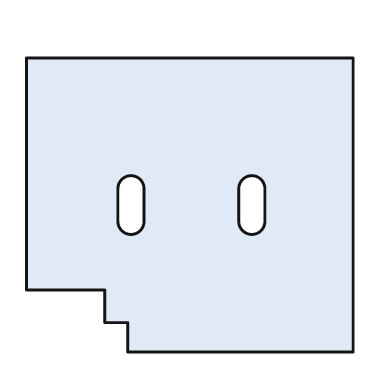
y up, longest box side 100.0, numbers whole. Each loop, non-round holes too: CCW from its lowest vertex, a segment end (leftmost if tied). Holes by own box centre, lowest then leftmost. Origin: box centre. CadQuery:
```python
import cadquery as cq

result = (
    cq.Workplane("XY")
    .moveTo(-19.0, -45.0)
    .lineTo(50.0, -45.0)
    .lineTo(50.0, 45.0)
    .lineTo(-50.0, 45.0)
    .lineTo(-50.0, -26.0)
    .lineTo(-26.0, -26.0)
    .lineTo(-26.0, -36.0)
    .lineTo(-19.0, -36.0)
    .close()
    .moveTo(-22.0, -5.0)
    .threePointArc((-18.0, -9.0), (-14.0, -5.0))
    .lineTo(-14.0, 5.0)
    .threePointArc((-18.0, 9.0), (-22.0, 5.0))
    .close()
    .moveTo(15.0, -5.0)
    .threePointArc((19.0, -9.0), (23.0, -5.0))
    .lineTo(23.0, 5.0)
    .threePointArc((19.0, 9.0), (15.0, 5.0))
    .close()
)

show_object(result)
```